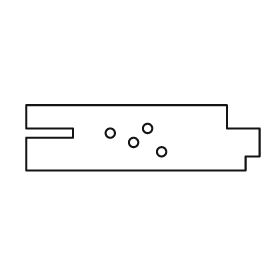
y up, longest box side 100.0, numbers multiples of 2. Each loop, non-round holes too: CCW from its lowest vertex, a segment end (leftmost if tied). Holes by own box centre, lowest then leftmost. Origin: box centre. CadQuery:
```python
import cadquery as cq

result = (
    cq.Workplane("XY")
    .moveTo(-50.0, -14.0)
    .lineTo(44.0, -14.0)
    .lineTo(44.0, -8.0)
    .lineTo(50.0, -8.0)
    .lineTo(50.0, 4.0)
    .lineTo(36.0, 4.0)
    .lineTo(36.0, 14.0)
    .lineTo(-50.0, 14.0)
    .lineTo(-50.0, 4.0)
    .lineTo(-30.0, 4.0)
    .lineTo(-30.0, 0.0)
    .lineTo(-50.0, 0.0)
    .close()
    .moveTo(8.0, -6.0)
    .circle(2.0)
    .moveTo(-4.0, -2.0)
    .circle(2.0)
    .moveTo(-14.0, 2.0)
    .circle(2.0)
    .moveTo(2.0, 4.0)
    .circle(2.0)
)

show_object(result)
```